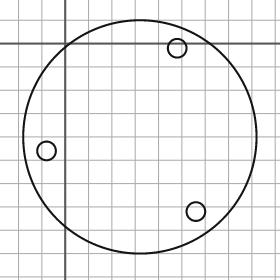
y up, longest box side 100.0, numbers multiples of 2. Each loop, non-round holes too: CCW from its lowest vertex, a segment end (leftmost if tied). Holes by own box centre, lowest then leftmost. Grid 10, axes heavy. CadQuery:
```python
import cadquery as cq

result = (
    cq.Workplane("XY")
    .moveTo(32.0, -40.0)
    .circle(50.0)
    .moveTo(56.0, -72.0)
    .circle(4.0)
    .moveTo(-8.0, -46.0)
    .circle(4.0)
    .moveTo(48.0, -2.0)
    .circle(4.0)
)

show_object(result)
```